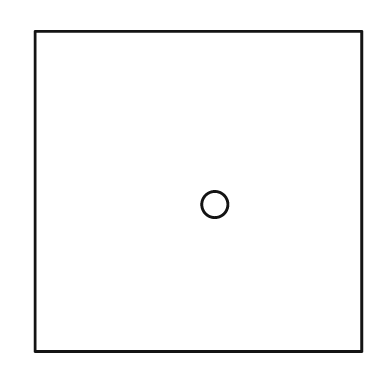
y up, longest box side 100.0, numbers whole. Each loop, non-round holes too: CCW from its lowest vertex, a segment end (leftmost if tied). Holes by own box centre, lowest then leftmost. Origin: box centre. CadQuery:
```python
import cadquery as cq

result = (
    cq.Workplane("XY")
    .moveTo(-50.0, -49.0)
    .lineTo(50.0, -49.0)
    .lineTo(50.0, 49.0)
    .lineTo(-50.0, 49.0)
    .close()
    .moveTo(5.0, -4.0)
    .circle(4.0)
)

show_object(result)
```